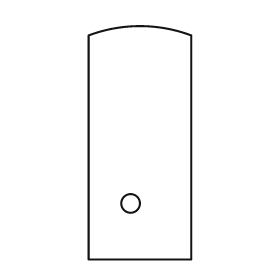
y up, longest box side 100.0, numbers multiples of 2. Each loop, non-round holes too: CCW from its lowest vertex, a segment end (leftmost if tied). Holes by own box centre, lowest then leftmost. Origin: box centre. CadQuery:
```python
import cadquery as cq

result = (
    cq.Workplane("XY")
    .moveTo(-22.0, -50.0)
    .lineTo(22.0, -50.0)
    .lineTo(22.0, 46.0)
    .threePointArc((0.0, 50.0), (-22.0, 46.0))
    .close()
    .moveTo(-4.0, -26.0)
    .circle(4.0)
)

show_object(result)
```